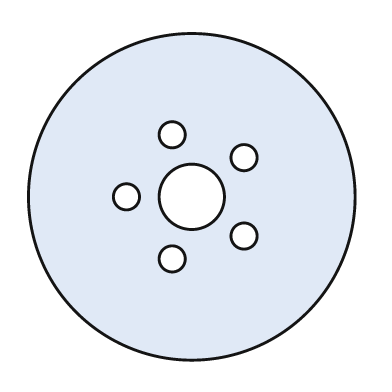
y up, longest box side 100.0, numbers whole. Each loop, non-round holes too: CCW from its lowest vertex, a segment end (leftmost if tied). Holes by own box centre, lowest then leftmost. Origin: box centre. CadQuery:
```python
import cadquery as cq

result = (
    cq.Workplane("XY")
    .moveTo(0.0, 0.0)
    .circle(50.0)
    .moveTo(-6.0, -19.0)
    .circle(4.0)
    .moveTo(16.0, -12.0)
    .circle(4.0)
    .moveTo(-20.0, 0.0)
    .circle(4.0)
    .moveTo(0.0, 0.0)
    .circle(10.0)
    .moveTo(16.0, 12.0)
    .circle(4.0)
    .moveTo(-6.0, 19.0)
    .circle(4.0)
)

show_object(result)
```